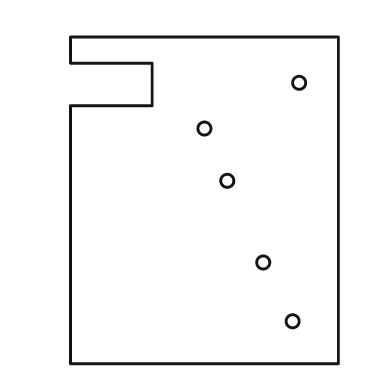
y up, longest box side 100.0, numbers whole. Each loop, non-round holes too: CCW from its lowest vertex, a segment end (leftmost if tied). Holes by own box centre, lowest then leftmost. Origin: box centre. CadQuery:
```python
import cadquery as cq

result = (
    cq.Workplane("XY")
    .moveTo(-41.0, -50.0)
    .lineTo(41.0, -50.0)
    .lineTo(41.0, 50.0)
    .lineTo(-41.0, 50.0)
    .lineTo(-41.0, 42.0)
    .lineTo(-16.0, 42.0)
    .lineTo(-16.0, 29.0)
    .lineTo(-41.0, 29.0)
    .close()
    .moveTo(27.0, -37.0)
    .circle(2.0)
    .moveTo(18.0, -19.0)
    .circle(2.0)
    .moveTo(7.0, 6.0)
    .circle(2.0)
    .moveTo(0.0, 22.0)
    .circle(2.0)
    .moveTo(29.0, 36.0)
    .circle(2.0)
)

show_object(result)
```